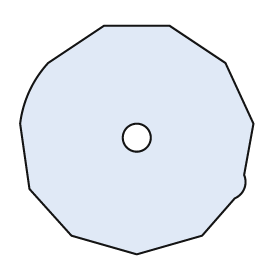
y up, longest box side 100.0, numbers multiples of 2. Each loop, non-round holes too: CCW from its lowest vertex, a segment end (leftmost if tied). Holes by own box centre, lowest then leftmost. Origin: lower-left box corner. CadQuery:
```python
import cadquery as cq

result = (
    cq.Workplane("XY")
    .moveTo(50.0, 0.0)
    .lineTo(78.0, 8.0)
    .lineTo(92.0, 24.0)
    .threePointArc((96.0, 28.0), (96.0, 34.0))
    .lineTo(100.0, 56.0)
    .lineTo(88.0, 82.0)
    .lineTo(64.0, 98.0)
    .lineTo(36.0, 98.0)
    .lineTo(12.0, 82.0)
    .threePointArc((4.0, 70.0), (0.0, 56.0))
    .lineTo(4.0, 28.0)
    .lineTo(22.0, 8.0)
    .close()
    .moveTo(50.0, 50.0)
    .circle(6.0)
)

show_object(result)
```